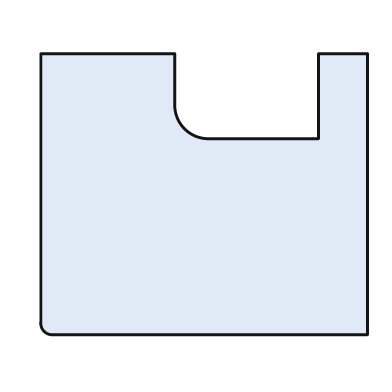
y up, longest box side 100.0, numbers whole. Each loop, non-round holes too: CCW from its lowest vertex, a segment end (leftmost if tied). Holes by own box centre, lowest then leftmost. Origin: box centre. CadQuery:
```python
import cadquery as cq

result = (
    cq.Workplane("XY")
    .moveTo(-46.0, -43.0)
    .lineTo(50.0, -43.0)
    .lineTo(50.0, 43.0)
    .lineTo(35.0, 43.0)
    .lineTo(35.0, 17.0)
    .lineTo(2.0, 17.0)
    .threePointArc((-6.0, 20.0), (-9.0, 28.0))
    .lineTo(-9.0, 43.0)
    .lineTo(-50.0, 43.0)
    .lineTo(-50.0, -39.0)
    .threePointArc((-49.0, -42.0), (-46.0, -43.0))
    .close()
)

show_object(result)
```